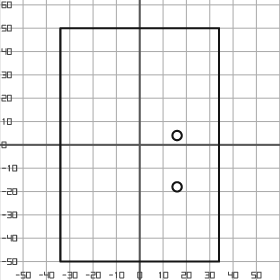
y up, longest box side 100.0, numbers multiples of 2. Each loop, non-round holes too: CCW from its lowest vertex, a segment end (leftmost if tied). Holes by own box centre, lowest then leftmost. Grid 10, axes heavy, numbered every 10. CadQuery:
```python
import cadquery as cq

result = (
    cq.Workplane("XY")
    .moveTo(-34.0, -50.0)
    .lineTo(34.0, -50.0)
    .lineTo(34.0, 50.0)
    .lineTo(-34.0, 50.0)
    .close()
    .moveTo(16.0, -18.0)
    .circle(2.0)
    .moveTo(16.0, 4.0)
    .circle(2.0)
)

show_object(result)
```